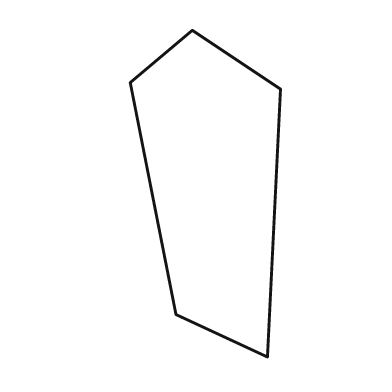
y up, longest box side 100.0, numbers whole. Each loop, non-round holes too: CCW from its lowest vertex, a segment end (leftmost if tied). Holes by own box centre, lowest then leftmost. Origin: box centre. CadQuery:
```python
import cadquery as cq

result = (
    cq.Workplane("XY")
    .moveTo(19.0, -50.0)
    .lineTo(23.0, 32.0)
    .lineTo(-4.0, 50.0)
    .lineTo(-23.0, 34.0)
    .lineTo(-9.0, -37.0)
    .close()
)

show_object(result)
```